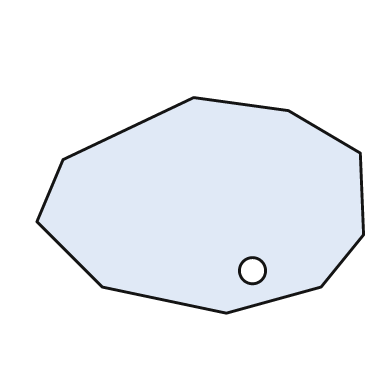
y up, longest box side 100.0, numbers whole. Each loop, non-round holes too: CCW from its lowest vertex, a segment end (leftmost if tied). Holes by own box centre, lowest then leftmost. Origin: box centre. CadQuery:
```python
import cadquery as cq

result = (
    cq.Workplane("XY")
    .moveTo(8.0, -33.0)
    .lineTo(37.0, -25.0)
    .lineTo(50.0, -9.0)
    .lineTo(49.0, 16.0)
    .lineTo(27.0, 29.0)
    .lineTo(-2.0, 33.0)
    .lineTo(-42.0, 14.0)
    .lineTo(-50.0, -5.0)
    .lineTo(-30.0, -25.0)
    .close()
    .moveTo(16.0, -20.0)
    .circle(4.0)
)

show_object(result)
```